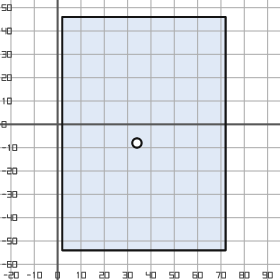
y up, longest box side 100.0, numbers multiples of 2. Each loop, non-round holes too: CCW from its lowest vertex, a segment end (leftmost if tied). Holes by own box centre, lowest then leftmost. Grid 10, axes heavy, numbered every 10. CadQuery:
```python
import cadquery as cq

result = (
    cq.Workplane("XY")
    .moveTo(2.0, -54.0)
    .lineTo(72.0, -54.0)
    .lineTo(72.0, 46.0)
    .lineTo(2.0, 46.0)
    .close()
    .moveTo(34.0, -8.0)
    .circle(2.0)
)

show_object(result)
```